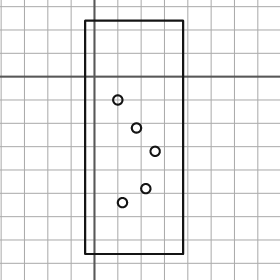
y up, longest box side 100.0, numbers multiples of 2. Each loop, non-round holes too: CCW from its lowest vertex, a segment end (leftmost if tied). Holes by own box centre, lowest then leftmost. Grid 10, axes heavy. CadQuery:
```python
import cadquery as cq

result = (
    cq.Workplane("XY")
    .moveTo(-4.0, -76.0)
    .lineTo(38.0, -76.0)
    .lineTo(38.0, 24.0)
    .lineTo(-4.0, 24.0)
    .close()
    .moveTo(12.0, -54.0)
    .circle(2.0)
    .moveTo(22.0, -48.0)
    .circle(2.0)
    .moveTo(26.0, -32.0)
    .circle(2.0)
    .moveTo(18.0, -22.0)
    .circle(2.0)
    .moveTo(10.0, -10.0)
    .circle(2.0)
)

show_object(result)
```